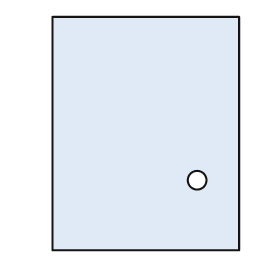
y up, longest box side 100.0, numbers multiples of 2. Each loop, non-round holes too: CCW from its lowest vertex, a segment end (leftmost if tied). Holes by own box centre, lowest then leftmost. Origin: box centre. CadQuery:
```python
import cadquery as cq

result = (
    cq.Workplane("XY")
    .moveTo(-40.0, -50.0)
    .lineTo(40.0, -50.0)
    .lineTo(40.0, 50.0)
    .lineTo(-40.0, 50.0)
    .close()
    .moveTo(22.0, -20.0)
    .circle(4.0)
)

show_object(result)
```